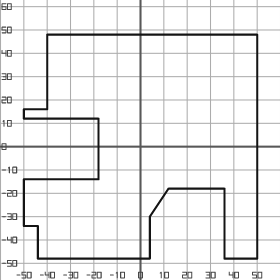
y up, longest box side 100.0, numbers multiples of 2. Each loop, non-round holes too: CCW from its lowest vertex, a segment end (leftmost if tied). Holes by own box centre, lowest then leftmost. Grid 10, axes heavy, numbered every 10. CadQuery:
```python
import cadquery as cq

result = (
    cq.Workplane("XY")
    .moveTo(-44.0, -48.0)
    .lineTo(4.0, -48.0)
    .lineTo(4.0, -30.0)
    .lineTo(12.0, -18.0)
    .lineTo(36.0, -18.0)
    .lineTo(36.0, -48.0)
    .lineTo(50.0, -48.0)
    .lineTo(50.0, 48.0)
    .lineTo(-40.0, 48.0)
    .lineTo(-40.0, 16.0)
    .lineTo(-50.0, 16.0)
    .lineTo(-50.0, 12.0)
    .lineTo(-18.0, 12.0)
    .lineTo(-18.0, -14.0)
    .lineTo(-50.0, -14.0)
    .lineTo(-50.0, -34.0)
    .lineTo(-44.0, -34.0)
    .close()
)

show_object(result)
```